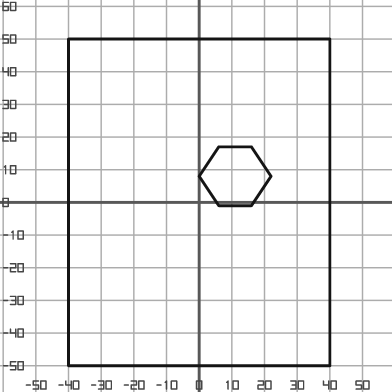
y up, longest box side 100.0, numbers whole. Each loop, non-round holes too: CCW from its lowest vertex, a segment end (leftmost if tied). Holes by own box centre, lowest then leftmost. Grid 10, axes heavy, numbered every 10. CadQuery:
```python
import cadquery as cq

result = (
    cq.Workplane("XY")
    .moveTo(-40.0, -50.0)
    .lineTo(40.0, -50.0)
    .lineTo(40.0, 50.0)
    .lineTo(-40.0, 50.0)
    .close()
    .moveTo(6.0, -1.0)
    .lineTo(16.0, -1.0)
    .lineTo(22.0, 8.0)
    .lineTo(16.0, 17.0)
    .lineTo(6.0, 17.0)
    .lineTo(0.0, 8.0)
    .close()
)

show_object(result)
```